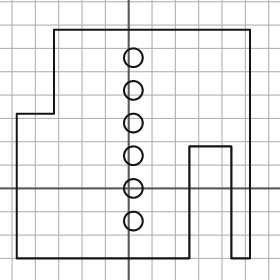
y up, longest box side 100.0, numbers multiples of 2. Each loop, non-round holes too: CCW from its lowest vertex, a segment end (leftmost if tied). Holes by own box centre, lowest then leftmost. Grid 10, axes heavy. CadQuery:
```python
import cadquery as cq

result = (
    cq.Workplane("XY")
    .moveTo(-48.0, -30.0)
    .lineTo(26.0, -30.0)
    .lineTo(26.0, 18.0)
    .lineTo(44.0, 18.0)
    .lineTo(44.0, -30.0)
    .lineTo(52.0, -30.0)
    .lineTo(52.0, 68.0)
    .lineTo(-32.0, 68.0)
    .lineTo(-32.0, 32.0)
    .lineTo(-48.0, 32.0)
    .close()
    .moveTo(2.0, -14.0)
    .circle(4.0)
    .moveTo(2.0, 0.0)
    .circle(4.0)
    .moveTo(2.0, 14.0)
    .circle(4.0)
    .moveTo(2.0, 28.0)
    .circle(4.0)
    .moveTo(2.0, 42.0)
    .circle(4.0)
    .moveTo(2.0, 56.0)
    .circle(4.0)
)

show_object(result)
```